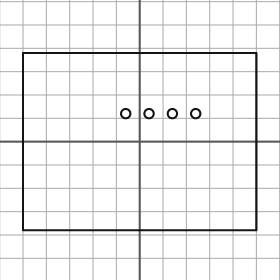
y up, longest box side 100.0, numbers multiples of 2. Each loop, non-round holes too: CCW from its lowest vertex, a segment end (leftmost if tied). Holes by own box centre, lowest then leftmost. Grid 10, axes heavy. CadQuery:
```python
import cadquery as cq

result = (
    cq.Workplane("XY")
    .moveTo(-50.0, -38.0)
    .lineTo(50.0, -38.0)
    .lineTo(50.0, 38.0)
    .lineTo(-50.0, 38.0)
    .close()
    .moveTo(-6.0, 12.0)
    .circle(2.0)
    .moveTo(4.0, 12.0)
    .circle(2.0)
    .moveTo(14.0, 12.0)
    .circle(2.0)
    .moveTo(24.0, 12.0)
    .circle(2.0)
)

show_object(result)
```